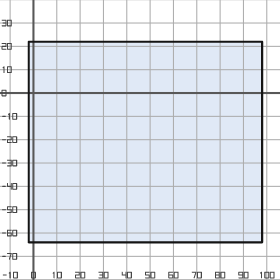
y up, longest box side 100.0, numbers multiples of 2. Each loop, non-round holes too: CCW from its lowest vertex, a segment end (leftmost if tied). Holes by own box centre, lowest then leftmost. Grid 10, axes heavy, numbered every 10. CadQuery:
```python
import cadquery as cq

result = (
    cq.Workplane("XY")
    .moveTo(-2.0, -64.0)
    .lineTo(98.0, -64.0)
    .lineTo(98.0, 22.0)
    .lineTo(-2.0, 22.0)
    .close()
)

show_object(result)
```